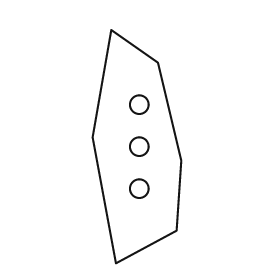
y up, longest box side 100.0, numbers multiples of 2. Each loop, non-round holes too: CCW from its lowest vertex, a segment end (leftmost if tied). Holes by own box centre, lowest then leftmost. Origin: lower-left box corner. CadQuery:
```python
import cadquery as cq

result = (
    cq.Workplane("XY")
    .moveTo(10.0, 0.0)
    .lineTo(36.0, 14.0)
    .lineTo(38.0, 44.0)
    .lineTo(28.0, 86.0)
    .lineTo(8.0, 100.0)
    .lineTo(0.0, 54.0)
    .close()
    .moveTo(20.0, 32.0)
    .circle(4.0)
    .moveTo(20.0, 50.0)
    .circle(4.0)
    .moveTo(20.0, 68.0)
    .circle(4.0)
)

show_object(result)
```